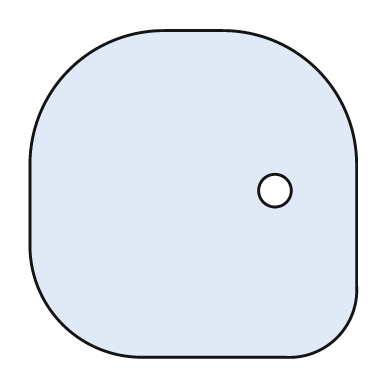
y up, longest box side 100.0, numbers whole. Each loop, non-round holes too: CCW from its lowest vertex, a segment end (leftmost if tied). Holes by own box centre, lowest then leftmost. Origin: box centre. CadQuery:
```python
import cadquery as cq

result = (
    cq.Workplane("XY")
    .moveTo(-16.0, -50.0)
    .lineTo(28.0, -50.0)
    .threePointArc((44.0, -44.0), (50.0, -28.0))
    .lineTo(50.0, 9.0)
    .threePointArc((38.0, 38.0), (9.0, 50.0))
    .lineTo(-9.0, 50.0)
    .threePointArc((-38.0, 38.0), (-50.0, 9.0))
    .lineTo(-50.0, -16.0)
    .threePointArc((-40.0, -40.0), (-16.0, -50.0))
    .close()
    .moveTo(25.0, 1.0)
    .circle(5.0)
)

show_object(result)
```